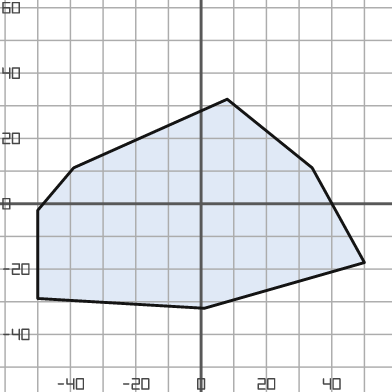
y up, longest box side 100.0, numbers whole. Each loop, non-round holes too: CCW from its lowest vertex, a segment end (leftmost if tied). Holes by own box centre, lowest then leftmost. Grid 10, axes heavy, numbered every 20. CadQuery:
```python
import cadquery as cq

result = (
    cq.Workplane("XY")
    .moveTo(1.0, -32.0)
    .lineTo(50.0, -18.0)
    .lineTo(34.0, 11.0)
    .lineTo(8.0, 32.0)
    .lineTo(-39.0, 11.0)
    .lineTo(-50.0, -2.0)
    .lineTo(-50.0, -29.0)
    .close()
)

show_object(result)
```